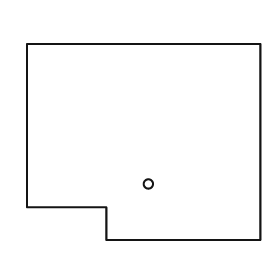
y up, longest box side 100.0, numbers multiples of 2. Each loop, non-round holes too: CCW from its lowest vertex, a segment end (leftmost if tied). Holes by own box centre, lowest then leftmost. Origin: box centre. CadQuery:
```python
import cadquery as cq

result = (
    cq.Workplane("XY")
    .moveTo(-16.0, -42.0)
    .lineTo(50.0, -42.0)
    .lineTo(50.0, 42.0)
    .lineTo(-50.0, 42.0)
    .lineTo(-50.0, -28.0)
    .lineTo(-16.0, -28.0)
    .close()
    .moveTo(2.0, -18.0)
    .circle(2.0)
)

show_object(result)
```